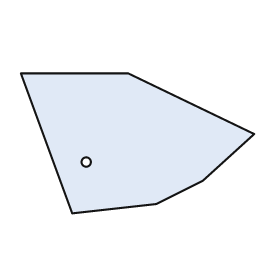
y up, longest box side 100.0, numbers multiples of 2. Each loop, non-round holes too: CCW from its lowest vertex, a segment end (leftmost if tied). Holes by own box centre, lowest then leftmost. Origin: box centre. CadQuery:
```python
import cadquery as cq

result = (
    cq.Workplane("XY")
    .moveTo(-28.0, -30.0)
    .lineTo(8.0, -26.0)
    .lineTo(28.0, -16.0)
    .lineTo(50.0, 4.0)
    .lineTo(-4.0, 30.0)
    .lineTo(-50.0, 30.0)
    .close()
    .moveTo(-22.0, -8.0)
    .circle(2.0)
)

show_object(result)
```